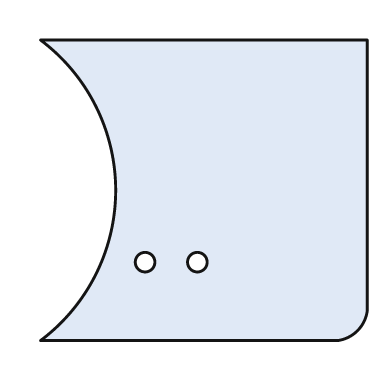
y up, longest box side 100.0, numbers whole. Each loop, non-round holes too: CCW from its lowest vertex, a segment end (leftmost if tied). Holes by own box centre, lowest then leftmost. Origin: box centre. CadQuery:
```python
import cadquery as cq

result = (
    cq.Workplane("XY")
    .moveTo(-50.0, -46.0)
    .lineTo(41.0, -46.0)
    .threePointArc((47.0, -43.0), (50.0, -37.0))
    .lineTo(50.0, 46.0)
    .lineTo(-50.0, 46.0)
    .threePointArc((-27.0, 0.0), (-50.0, -46.0))
    .close()
    .moveTo(-18.0, -22.0)
    .circle(3.0)
    .moveTo(-2.0, -22.0)
    .circle(3.0)
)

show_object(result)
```